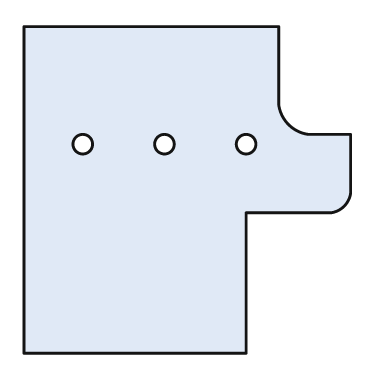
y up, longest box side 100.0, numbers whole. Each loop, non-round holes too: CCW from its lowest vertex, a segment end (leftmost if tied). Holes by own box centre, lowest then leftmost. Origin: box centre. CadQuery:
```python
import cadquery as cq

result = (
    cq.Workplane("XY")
    .moveTo(-50.0, -50.0)
    .lineTo(18.0, -50.0)
    .lineTo(18.0, -7.0)
    .lineTo(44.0, -7.0)
    .threePointArc((48.0, -5.0), (50.0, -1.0))
    .lineTo(50.0, 17.0)
    .lineTo(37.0, 17.0)
    .threePointArc((31.0, 20.0), (28.0, 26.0))
    .lineTo(28.0, 50.0)
    .lineTo(-50.0, 50.0)
    .close()
    .moveTo(-32.0, 14.0)
    .circle(3.0)
    .moveTo(-7.0, 14.0)
    .circle(3.0)
    .moveTo(18.0, 14.0)
    .circle(3.0)
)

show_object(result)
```